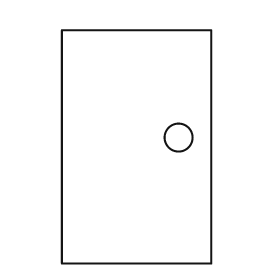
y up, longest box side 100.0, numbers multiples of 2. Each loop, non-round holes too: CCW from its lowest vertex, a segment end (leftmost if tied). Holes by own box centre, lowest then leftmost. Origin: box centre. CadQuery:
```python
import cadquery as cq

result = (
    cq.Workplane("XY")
    .moveTo(-32.0, -50.0)
    .lineTo(32.0, -50.0)
    .lineTo(32.0, 50.0)
    .lineTo(-32.0, 50.0)
    .close()
    .moveTo(18.0, 4.0)
    .circle(6.0)
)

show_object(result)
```